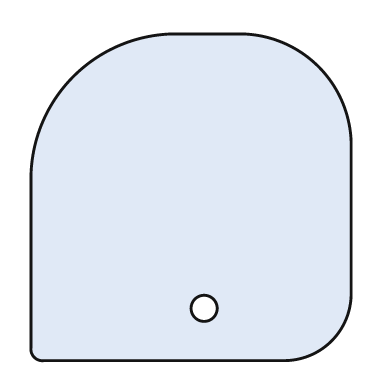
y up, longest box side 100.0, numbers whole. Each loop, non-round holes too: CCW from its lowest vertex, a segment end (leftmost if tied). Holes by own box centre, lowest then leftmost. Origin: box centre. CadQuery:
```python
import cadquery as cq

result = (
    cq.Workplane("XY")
    .moveTo(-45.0, -50.0)
    .lineTo(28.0, -50.0)
    .threePointArc((43.0, -44.0), (49.0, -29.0))
    .lineTo(49.0, 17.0)
    .threePointArc((39.0, 40.0), (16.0, 50.0))
    .lineTo(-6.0, 50.0)
    .threePointArc((-36.0, 37.0), (-49.0, 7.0))
    .lineTo(-49.0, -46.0)
    .threePointArc((-48.0, -49.0), (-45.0, -50.0))
    .close()
    .moveTo(4.0, -34.0)
    .circle(4.0)
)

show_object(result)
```